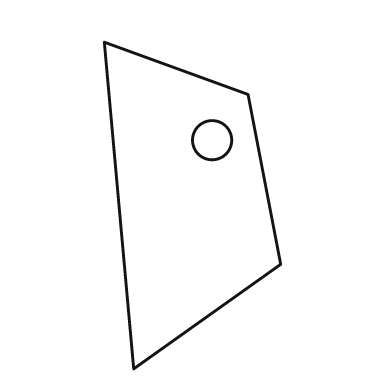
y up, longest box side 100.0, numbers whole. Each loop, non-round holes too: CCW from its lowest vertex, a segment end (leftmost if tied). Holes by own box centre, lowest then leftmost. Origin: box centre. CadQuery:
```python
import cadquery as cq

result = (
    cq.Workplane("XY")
    .moveTo(-18.0, -50.0)
    .lineTo(27.0, -18.0)
    .lineTo(17.0, 34.0)
    .lineTo(-27.0, 50.0)
    .close()
    .moveTo(6.0, 20.0)
    .circle(6.0)
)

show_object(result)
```